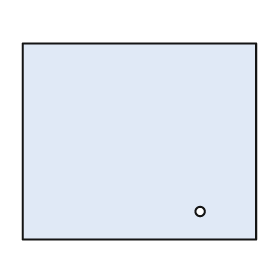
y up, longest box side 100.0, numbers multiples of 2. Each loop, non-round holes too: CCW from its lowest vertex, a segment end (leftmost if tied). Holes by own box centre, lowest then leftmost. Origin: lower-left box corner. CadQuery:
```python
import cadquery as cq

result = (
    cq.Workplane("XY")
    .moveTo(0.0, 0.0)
    .lineTo(100.0, 0.0)
    .lineTo(100.0, 84.0)
    .lineTo(0.0, 84.0)
    .close()
    .moveTo(76.0, 12.0)
    .circle(2.0)
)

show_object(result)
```